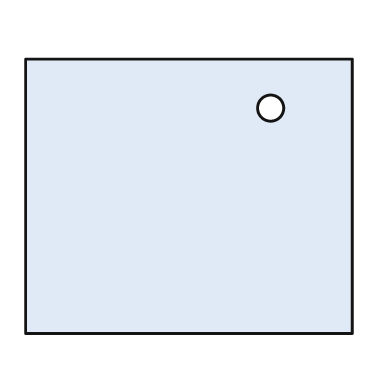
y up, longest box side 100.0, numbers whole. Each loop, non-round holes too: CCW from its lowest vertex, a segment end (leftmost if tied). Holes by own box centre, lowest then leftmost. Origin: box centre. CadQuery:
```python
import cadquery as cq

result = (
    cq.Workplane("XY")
    .moveTo(-50.0, -42.0)
    .lineTo(50.0, -42.0)
    .lineTo(50.0, 42.0)
    .lineTo(-50.0, 42.0)
    .close()
    .moveTo(25.0, 27.0)
    .circle(4.0)
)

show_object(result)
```